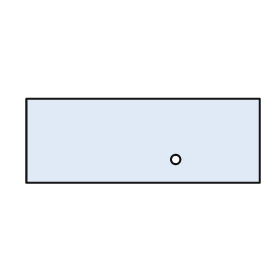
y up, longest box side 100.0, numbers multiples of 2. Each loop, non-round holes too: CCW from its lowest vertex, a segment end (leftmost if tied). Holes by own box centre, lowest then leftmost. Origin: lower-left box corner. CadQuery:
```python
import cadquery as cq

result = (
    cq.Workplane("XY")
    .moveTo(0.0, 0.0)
    .lineTo(100.0, 0.0)
    .lineTo(100.0, 36.0)
    .lineTo(0.0, 36.0)
    .close()
    .moveTo(64.0, 10.0)
    .circle(2.0)
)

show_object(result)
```